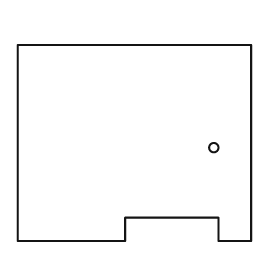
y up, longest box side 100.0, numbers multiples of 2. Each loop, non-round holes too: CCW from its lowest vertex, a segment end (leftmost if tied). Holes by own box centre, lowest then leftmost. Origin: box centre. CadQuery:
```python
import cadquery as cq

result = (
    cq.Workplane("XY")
    .moveTo(-50.0, -42.0)
    .lineTo(-4.0, -42.0)
    .lineTo(-4.0, -32.0)
    .lineTo(36.0, -32.0)
    .lineTo(36.0, -42.0)
    .lineTo(50.0, -42.0)
    .lineTo(50.0, 42.0)
    .lineTo(-50.0, 42.0)
    .close()
    .moveTo(34.0, -2.0)
    .circle(2.0)
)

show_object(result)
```